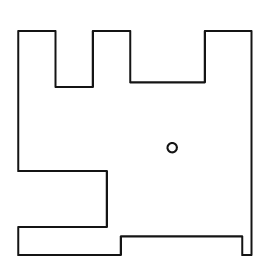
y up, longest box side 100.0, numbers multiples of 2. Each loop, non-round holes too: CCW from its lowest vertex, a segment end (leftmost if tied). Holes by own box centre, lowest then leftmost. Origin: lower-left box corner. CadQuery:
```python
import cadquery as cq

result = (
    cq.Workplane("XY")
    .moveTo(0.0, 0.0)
    .lineTo(44.0, 0.0)
    .lineTo(44.0, 8.0)
    .lineTo(96.0, 8.0)
    .lineTo(96.0, 0.0)
    .lineTo(100.0, 0.0)
    .lineTo(100.0, 96.0)
    .lineTo(80.0, 96.0)
    .lineTo(80.0, 74.0)
    .lineTo(48.0, 74.0)
    .lineTo(48.0, 96.0)
    .lineTo(32.0, 96.0)
    .lineTo(32.0, 72.0)
    .lineTo(16.0, 72.0)
    .lineTo(16.0, 96.0)
    .lineTo(0.0, 96.0)
    .lineTo(0.0, 36.0)
    .lineTo(38.0, 36.0)
    .lineTo(38.0, 12.0)
    .lineTo(0.0, 12.0)
    .close()
    .moveTo(66.0, 46.0)
    .circle(2.0)
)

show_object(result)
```